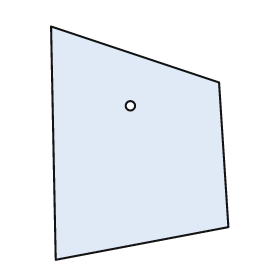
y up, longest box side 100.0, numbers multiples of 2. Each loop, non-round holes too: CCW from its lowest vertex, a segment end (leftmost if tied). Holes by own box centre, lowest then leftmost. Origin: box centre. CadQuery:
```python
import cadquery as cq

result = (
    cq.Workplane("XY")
    .moveTo(-36.0, -50.0)
    .lineTo(38.0, -36.0)
    .lineTo(34.0, 26.0)
    .lineTo(-38.0, 50.0)
    .close()
    .moveTo(-4.0, 16.0)
    .circle(2.0)
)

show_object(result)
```